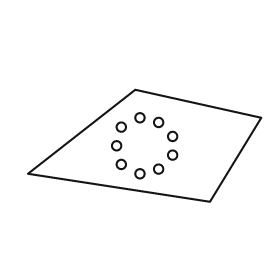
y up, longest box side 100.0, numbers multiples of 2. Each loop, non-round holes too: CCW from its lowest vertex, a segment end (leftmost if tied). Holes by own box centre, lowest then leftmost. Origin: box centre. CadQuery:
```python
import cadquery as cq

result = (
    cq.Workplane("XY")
    .moveTo(28.0, -24.0)
    .lineTo(50.0, 12.0)
    .lineTo(-4.0, 24.0)
    .lineTo(-50.0, -12.0)
    .close()
    .moveTo(-2.0, -12.0)
    .circle(2.0)
    .moveTo(6.0, -10.0)
    .circle(2.0)
    .moveTo(-10.0, -8.0)
    .circle(2.0)
    .moveTo(12.0, -4.0)
    .circle(2.0)
    .moveTo(-12.0, 0.0)
    .circle(2.0)
    .moveTo(12.0, 4.0)
    .circle(2.0)
    .moveTo(-10.0, 8.0)
    .circle(2.0)
    .moveTo(6.0, 10.0)
    .circle(2.0)
    .moveTo(-2.0, 12.0)
    .circle(2.0)
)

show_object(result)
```